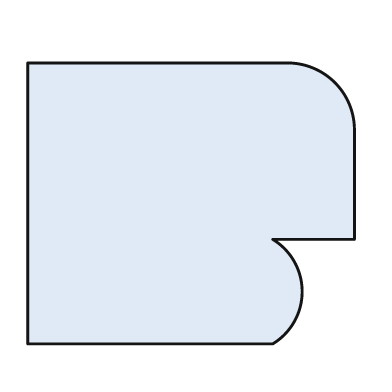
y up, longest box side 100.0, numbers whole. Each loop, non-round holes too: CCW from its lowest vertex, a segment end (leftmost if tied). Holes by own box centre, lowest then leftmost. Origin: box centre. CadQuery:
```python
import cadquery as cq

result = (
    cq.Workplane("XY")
    .moveTo(-50.0, -43.0)
    .lineTo(25.0, -43.0)
    .threePointArc((34.0, -27.0), (25.0, -11.0))
    .lineTo(50.0, -11.0)
    .lineTo(50.0, 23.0)
    .threePointArc((44.0, 37.0), (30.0, 43.0))
    .lineTo(-50.0, 43.0)
    .close()
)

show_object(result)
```